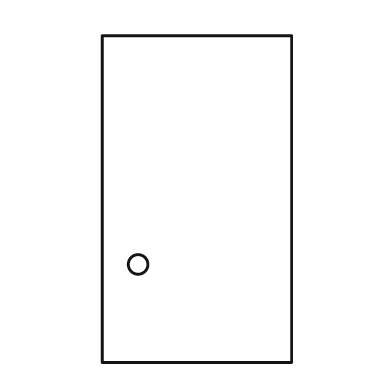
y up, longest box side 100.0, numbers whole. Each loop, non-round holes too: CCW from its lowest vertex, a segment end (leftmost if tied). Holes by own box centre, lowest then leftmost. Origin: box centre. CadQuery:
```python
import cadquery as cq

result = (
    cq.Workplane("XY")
    .moveTo(-29.0, -50.0)
    .lineTo(29.0, -50.0)
    .lineTo(29.0, 50.0)
    .lineTo(-29.0, 50.0)
    .close()
    .moveTo(-18.0, -20.0)
    .circle(3.0)
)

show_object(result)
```